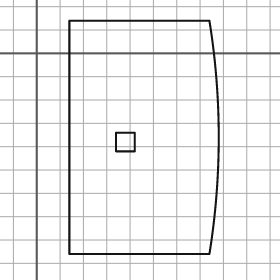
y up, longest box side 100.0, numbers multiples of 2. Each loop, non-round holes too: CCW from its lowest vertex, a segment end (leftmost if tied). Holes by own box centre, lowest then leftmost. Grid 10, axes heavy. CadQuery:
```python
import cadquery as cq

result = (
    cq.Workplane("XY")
    .moveTo(14.0, -86.0)
    .lineTo(74.0, -86.0)
    .threePointArc((78.0, -36.0), (74.0, 14.0))
    .lineTo(14.0, 14.0)
    .close()
    .moveTo(34.0, -42.0)
    .lineTo(42.0, -42.0)
    .lineTo(42.0, -34.0)
    .lineTo(34.0, -34.0)
    .close()
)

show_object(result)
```